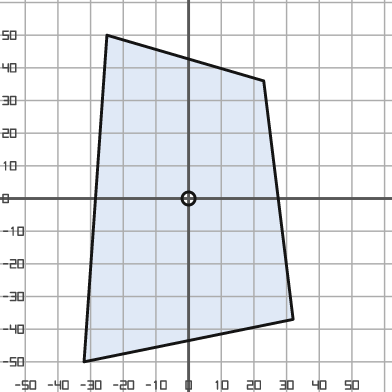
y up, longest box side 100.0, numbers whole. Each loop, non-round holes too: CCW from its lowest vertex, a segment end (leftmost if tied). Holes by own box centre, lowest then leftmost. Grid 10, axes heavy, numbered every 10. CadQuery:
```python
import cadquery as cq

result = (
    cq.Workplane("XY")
    .moveTo(-32.0, -50.0)
    .lineTo(32.0, -37.0)
    .lineTo(23.0, 36.0)
    .lineTo(-25.0, 50.0)
    .close()
    .moveTo(0.0, 0.0)
    .circle(2.0)
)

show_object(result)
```